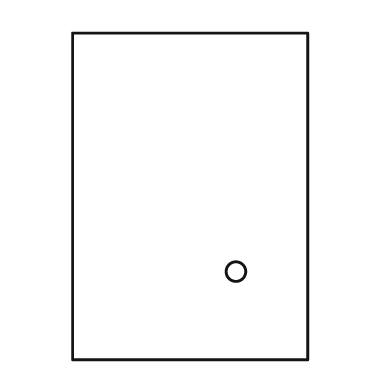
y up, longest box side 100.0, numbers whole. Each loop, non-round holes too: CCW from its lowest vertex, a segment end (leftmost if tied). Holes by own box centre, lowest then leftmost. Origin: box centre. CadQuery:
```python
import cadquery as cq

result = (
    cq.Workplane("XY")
    .moveTo(-36.0, -50.0)
    .lineTo(36.0, -50.0)
    .lineTo(36.0, 50.0)
    .lineTo(-36.0, 50.0)
    .close()
    .moveTo(14.0, -23.0)
    .circle(3.0)
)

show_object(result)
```